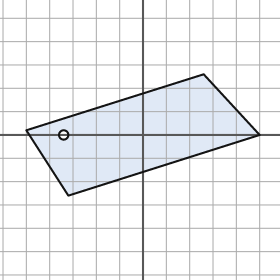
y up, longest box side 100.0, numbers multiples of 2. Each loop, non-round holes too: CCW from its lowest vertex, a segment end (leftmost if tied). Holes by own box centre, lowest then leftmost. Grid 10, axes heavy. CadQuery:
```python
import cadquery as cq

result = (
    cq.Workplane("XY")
    .moveTo(-32.0, -26.0)
    .lineTo(50.0, 0.0)
    .lineTo(26.0, 26.0)
    .lineTo(-50.0, 2.0)
    .close()
    .moveTo(-34.0, 0.0)
    .circle(2.0)
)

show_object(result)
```